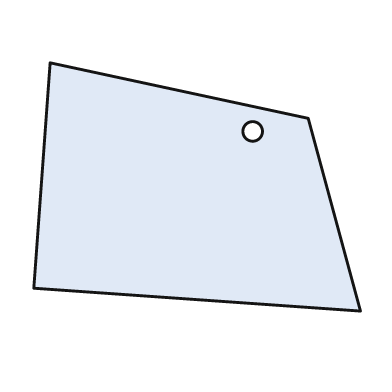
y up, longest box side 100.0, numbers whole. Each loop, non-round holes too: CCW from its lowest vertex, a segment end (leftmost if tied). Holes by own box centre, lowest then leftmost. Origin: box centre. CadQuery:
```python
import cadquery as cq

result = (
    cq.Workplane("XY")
    .moveTo(50.0, -38.0)
    .lineTo(34.0, 21.0)
    .lineTo(-45.0, 38.0)
    .lineTo(-50.0, -31.0)
    .close()
    .moveTo(17.0, 17.0)
    .circle(3.0)
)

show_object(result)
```